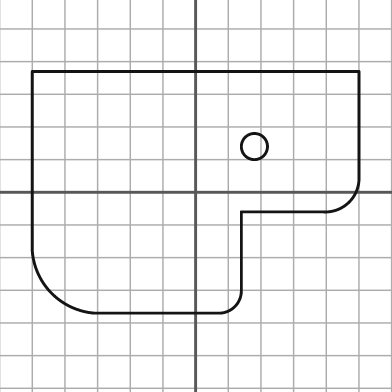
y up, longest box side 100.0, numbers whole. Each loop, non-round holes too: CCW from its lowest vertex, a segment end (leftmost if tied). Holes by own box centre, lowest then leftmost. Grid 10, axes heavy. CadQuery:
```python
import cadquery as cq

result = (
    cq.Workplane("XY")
    .moveTo(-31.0, -37.0)
    .lineTo(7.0, -37.0)
    .threePointArc((12.0, -35.0), (14.0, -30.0))
    .lineTo(14.0, -6.0)
    .lineTo(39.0, -6.0)
    .threePointArc((47.0, -3.0), (50.0, 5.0))
    .lineTo(50.0, 37.0)
    .lineTo(-50.0, 37.0)
    .lineTo(-50.0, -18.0)
    .threePointArc((-44.0, -31.0), (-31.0, -37.0))
    .close()
    .moveTo(18.0, 14.0)
    .circle(4.0)
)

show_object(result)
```